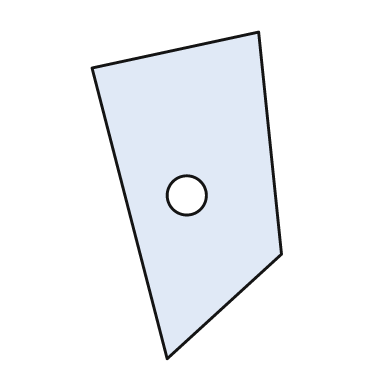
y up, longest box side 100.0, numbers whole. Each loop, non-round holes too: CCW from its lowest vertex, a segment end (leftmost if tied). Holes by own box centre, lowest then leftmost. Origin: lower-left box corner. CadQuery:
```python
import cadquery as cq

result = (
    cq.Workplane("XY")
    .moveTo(23.0, 0.0)
    .lineTo(58.0, 32.0)
    .lineTo(51.0, 100.0)
    .lineTo(0.0, 89.0)
    .close()
    .moveTo(29.0, 50.0)
    .circle(6.0)
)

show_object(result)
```